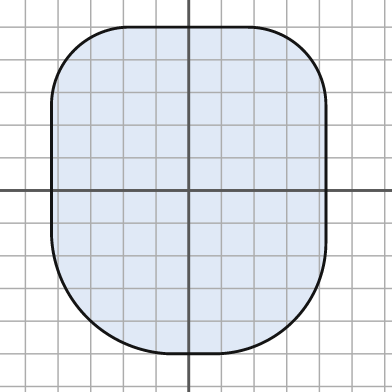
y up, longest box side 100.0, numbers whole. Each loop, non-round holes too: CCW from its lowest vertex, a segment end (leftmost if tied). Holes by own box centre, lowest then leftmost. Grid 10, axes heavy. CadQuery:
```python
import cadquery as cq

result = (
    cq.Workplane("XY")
    .moveTo(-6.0, -50.0)
    .lineTo(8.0, -50.0)
    .threePointArc((32.0, -40.0), (42.0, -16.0))
    .lineTo(42.0, 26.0)
    .threePointArc((35.0, 43.0), (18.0, 50.0))
    .lineTo(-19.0, 50.0)
    .threePointArc((-35.0, 43.0), (-42.0, 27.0))
    .lineTo(-42.0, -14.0)
    .threePointArc((-31.0, -39.0), (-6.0, -50.0))
    .close()
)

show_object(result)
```